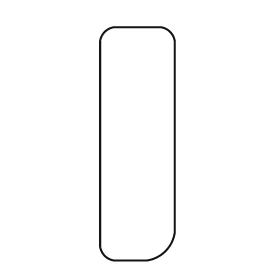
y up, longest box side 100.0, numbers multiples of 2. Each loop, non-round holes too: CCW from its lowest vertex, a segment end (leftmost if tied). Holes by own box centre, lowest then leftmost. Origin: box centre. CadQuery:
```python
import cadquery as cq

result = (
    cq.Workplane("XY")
    .moveTo(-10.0, -50.0)
    .lineTo(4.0, -50.0)
    .threePointArc((12.0, -46.0), (16.0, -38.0))
    .lineTo(16.0, 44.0)
    .threePointArc((14.0, 48.0), (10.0, 50.0))
    .lineTo(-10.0, 50.0)
    .threePointArc((-14.0, 48.0), (-16.0, 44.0))
    .lineTo(-16.0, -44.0)
    .threePointArc((-14.0, -48.0), (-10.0, -50.0))
    .close()
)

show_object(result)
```